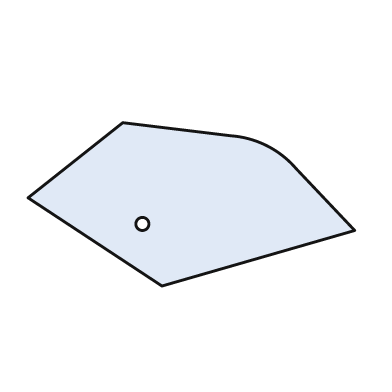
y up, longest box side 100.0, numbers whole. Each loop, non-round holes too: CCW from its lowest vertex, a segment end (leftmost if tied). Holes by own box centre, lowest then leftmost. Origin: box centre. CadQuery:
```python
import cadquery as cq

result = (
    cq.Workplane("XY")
    .moveTo(-9.0, -25.0)
    .lineTo(50.0, -8.0)
    .lineTo(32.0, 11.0)
    .threePointArc((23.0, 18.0), (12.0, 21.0))
    .lineTo(-21.0, 25.0)
    .lineTo(-50.0, 2.0)
    .close()
    .moveTo(-15.0, -6.0)
    .circle(2.0)
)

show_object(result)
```